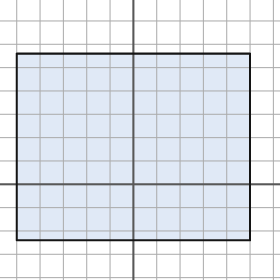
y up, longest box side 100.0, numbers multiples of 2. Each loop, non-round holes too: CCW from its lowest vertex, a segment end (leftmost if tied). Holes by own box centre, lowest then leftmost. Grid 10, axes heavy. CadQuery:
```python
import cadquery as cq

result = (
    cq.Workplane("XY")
    .moveTo(-50.0, -24.0)
    .lineTo(50.0, -24.0)
    .lineTo(50.0, 56.0)
    .lineTo(-50.0, 56.0)
    .close()
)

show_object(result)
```